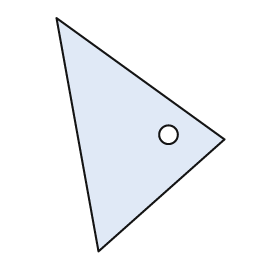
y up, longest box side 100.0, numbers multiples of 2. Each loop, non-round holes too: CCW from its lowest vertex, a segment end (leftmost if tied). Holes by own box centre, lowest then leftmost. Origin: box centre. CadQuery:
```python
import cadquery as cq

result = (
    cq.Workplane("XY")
    .moveTo(-18.0, -50.0)
    .lineTo(36.0, -2.0)
    .lineTo(-36.0, 50.0)
    .close()
    .moveTo(12.0, 0.0)
    .circle(4.0)
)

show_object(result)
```